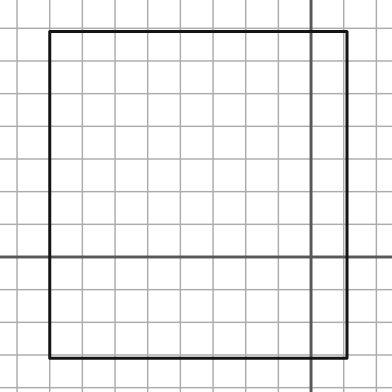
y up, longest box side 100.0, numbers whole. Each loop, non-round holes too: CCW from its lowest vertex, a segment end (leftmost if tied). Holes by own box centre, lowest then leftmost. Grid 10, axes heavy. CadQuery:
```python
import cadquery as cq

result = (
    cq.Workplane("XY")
    .moveTo(-80.0, -31.0)
    .lineTo(11.0, -31.0)
    .lineTo(11.0, 69.0)
    .lineTo(-80.0, 69.0)
    .close()
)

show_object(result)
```